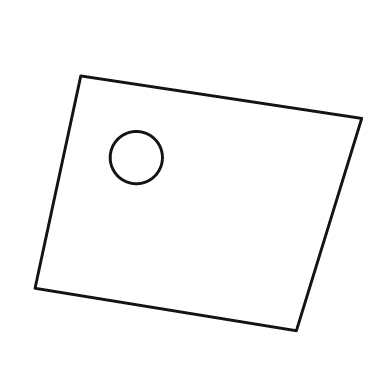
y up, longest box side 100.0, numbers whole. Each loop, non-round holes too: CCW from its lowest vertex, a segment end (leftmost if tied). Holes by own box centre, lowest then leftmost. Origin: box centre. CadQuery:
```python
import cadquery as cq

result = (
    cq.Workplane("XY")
    .moveTo(30.0, -39.0)
    .lineTo(50.0, 26.0)
    .lineTo(-36.0, 39.0)
    .lineTo(-50.0, -26.0)
    .close()
    .moveTo(-19.0, 14.0)
    .circle(8.0)
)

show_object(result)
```